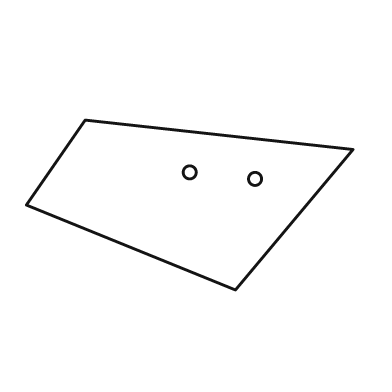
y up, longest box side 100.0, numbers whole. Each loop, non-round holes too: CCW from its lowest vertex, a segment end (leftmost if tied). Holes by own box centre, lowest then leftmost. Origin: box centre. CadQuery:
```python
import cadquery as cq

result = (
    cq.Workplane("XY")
    .moveTo(14.0, -26.0)
    .lineTo(50.0, 17.0)
    .lineTo(-32.0, 26.0)
    .lineTo(-50.0, 0.0)
    .close()
    .moveTo(20.0, 8.0)
    .circle(2.0)
    .moveTo(0.0, 10.0)
    .circle(2.0)
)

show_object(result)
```